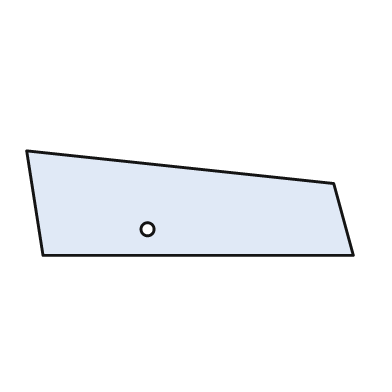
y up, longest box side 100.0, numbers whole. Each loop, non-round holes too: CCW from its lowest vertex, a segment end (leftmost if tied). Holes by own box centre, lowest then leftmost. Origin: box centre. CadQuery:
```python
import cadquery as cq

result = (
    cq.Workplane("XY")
    .moveTo(-45.0, -16.0)
    .lineTo(50.0, -16.0)
    .lineTo(44.0, 6.0)
    .lineTo(-50.0, 16.0)
    .close()
    .moveTo(-13.0, -8.0)
    .circle(2.0)
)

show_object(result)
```